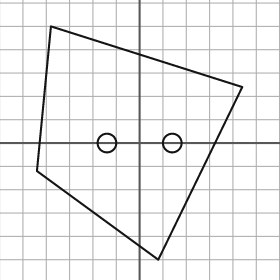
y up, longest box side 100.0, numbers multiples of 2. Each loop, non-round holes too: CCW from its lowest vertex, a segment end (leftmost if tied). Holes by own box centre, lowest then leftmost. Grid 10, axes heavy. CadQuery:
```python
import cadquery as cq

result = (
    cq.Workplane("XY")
    .moveTo(8.0, -50.0)
    .lineTo(44.0, 24.0)
    .lineTo(-38.0, 50.0)
    .lineTo(-44.0, -12.0)
    .close()
    .moveTo(-14.0, 0.0)
    .circle(4.0)
    .moveTo(14.0, 0.0)
    .circle(4.0)
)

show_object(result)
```